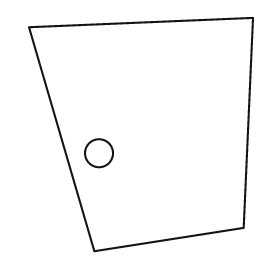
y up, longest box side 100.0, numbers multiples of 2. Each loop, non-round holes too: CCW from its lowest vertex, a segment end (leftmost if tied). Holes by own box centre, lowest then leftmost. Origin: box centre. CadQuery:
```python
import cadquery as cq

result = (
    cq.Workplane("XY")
    .moveTo(-20.0, -50.0)
    .lineTo(44.0, -40.0)
    .lineTo(48.0, 50.0)
    .lineTo(-48.0, 46.0)
    .close()
    .moveTo(-18.0, -8.0)
    .circle(6.0)
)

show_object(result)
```